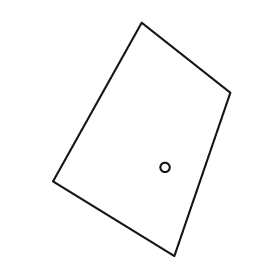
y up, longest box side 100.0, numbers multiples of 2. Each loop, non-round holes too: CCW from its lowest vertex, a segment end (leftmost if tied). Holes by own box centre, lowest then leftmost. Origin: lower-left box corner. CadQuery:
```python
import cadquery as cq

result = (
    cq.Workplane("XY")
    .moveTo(52.0, 0.0)
    .lineTo(76.0, 70.0)
    .lineTo(38.0, 100.0)
    .lineTo(0.0, 32.0)
    .close()
    .moveTo(48.0, 38.0)
    .circle(2.0)
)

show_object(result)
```